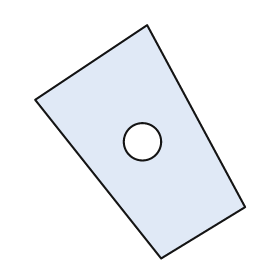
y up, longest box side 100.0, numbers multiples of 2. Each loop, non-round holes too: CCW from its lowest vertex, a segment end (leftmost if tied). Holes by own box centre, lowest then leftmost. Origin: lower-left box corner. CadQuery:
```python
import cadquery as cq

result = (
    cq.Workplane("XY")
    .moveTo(54.0, 0.0)
    .lineTo(90.0, 22.0)
    .lineTo(48.0, 100.0)
    .lineTo(0.0, 68.0)
    .close()
    .moveTo(46.0, 50.0)
    .circle(8.0)
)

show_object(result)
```